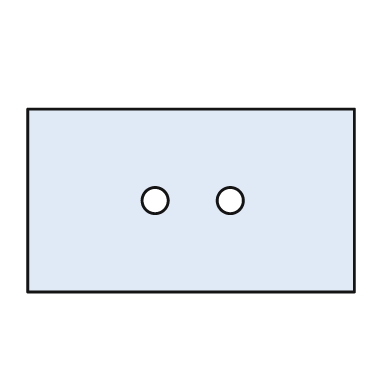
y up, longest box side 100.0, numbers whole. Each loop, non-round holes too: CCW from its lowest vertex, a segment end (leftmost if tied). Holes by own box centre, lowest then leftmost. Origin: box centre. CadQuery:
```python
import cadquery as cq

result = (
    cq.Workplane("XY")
    .moveTo(-50.0, -28.0)
    .lineTo(50.0, -28.0)
    .lineTo(50.0, 28.0)
    .lineTo(-50.0, 28.0)
    .close()
    .moveTo(-11.0, 0.0)
    .circle(4.0)
    .moveTo(12.0, 0.0)
    .circle(4.0)
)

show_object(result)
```